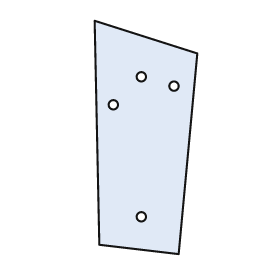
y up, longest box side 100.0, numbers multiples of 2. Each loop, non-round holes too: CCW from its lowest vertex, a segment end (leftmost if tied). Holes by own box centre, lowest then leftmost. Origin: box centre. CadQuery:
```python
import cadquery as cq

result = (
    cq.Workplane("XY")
    .moveTo(14.0, -50.0)
    .lineTo(22.0, 36.0)
    .lineTo(-22.0, 50.0)
    .lineTo(-20.0, -46.0)
    .close()
    .moveTo(-2.0, -34.0)
    .circle(2.0)
    .moveTo(-14.0, 14.0)
    .circle(2.0)
    .moveTo(12.0, 22.0)
    .circle(2.0)
    .moveTo(-2.0, 26.0)
    .circle(2.0)
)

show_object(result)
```